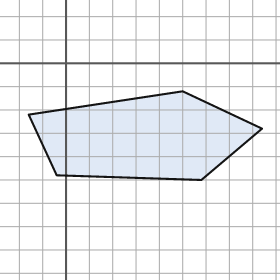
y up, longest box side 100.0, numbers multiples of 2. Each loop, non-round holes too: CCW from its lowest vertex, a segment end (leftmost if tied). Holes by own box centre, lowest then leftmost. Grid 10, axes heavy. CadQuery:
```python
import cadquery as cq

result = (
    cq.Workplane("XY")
    .moveTo(58.0, -50.0)
    .lineTo(84.0, -28.0)
    .lineTo(50.0, -12.0)
    .lineTo(-16.0, -22.0)
    .lineTo(-4.0, -48.0)
    .close()
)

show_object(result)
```